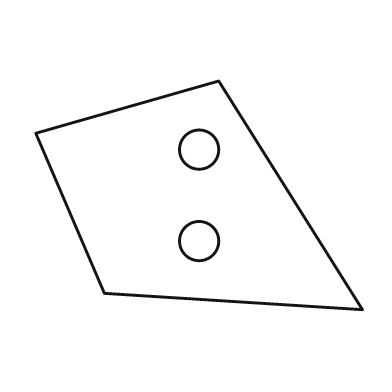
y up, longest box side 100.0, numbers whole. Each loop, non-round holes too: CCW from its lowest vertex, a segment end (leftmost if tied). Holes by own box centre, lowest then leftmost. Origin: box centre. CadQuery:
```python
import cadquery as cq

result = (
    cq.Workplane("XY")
    .moveTo(50.0, -35.0)
    .lineTo(6.0, 35.0)
    .lineTo(-50.0, 19.0)
    .lineTo(-29.0, -30.0)
    .close()
    .moveTo(0.0, -14.0)
    .circle(6.0)
    .moveTo(0.0, 14.0)
    .circle(6.0)
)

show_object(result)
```